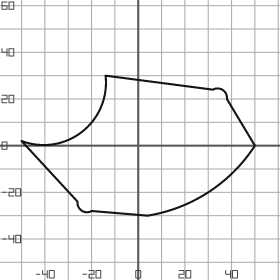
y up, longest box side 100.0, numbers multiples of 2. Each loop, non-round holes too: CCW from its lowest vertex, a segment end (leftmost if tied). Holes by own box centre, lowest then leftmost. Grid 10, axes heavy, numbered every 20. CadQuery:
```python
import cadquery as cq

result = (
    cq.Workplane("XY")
    .moveTo(4.0, -30.0)
    .threePointArc((30.0, -20.0), (50.0, 0.0))
    .lineTo(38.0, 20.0)
    .threePointArc((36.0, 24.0), (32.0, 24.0))
    .lineTo(-14.0, 30.0)
    .threePointArc((-24.0, 6.0), (-50.0, 2.0))
    .lineTo(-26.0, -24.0)
    .threePointArc((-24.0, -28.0), (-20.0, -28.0))
    .close()
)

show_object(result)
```